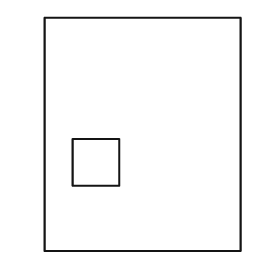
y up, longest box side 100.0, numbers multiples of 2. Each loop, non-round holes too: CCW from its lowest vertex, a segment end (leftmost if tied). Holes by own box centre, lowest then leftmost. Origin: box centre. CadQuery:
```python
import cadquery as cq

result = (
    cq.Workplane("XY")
    .moveTo(-42.0, -50.0)
    .lineTo(42.0, -50.0)
    .lineTo(42.0, 50.0)
    .lineTo(-42.0, 50.0)
    .close()
    .moveTo(-30.0, -22.0)
    .lineTo(-10.0, -22.0)
    .lineTo(-10.0, -2.0)
    .lineTo(-30.0, -2.0)
    .close()
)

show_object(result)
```